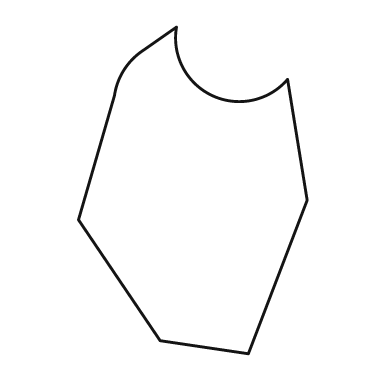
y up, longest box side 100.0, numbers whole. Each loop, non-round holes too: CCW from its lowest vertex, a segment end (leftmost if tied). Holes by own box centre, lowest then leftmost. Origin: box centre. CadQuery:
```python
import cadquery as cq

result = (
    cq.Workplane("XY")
    .moveTo(17.0, -50.0)
    .lineTo(35.0, -3.0)
    .lineTo(29.0, 34.0)
    .threePointArc((6.0, 29.0), (-5.0, 50.0))
    .lineTo(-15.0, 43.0)
    .threePointArc((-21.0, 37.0), (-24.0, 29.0))
    .lineTo(-35.0, -9.0)
    .lineTo(-10.0, -46.0)
    .close()
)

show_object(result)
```